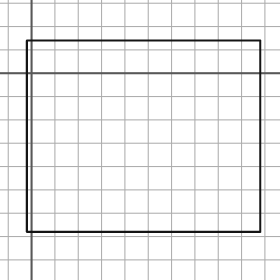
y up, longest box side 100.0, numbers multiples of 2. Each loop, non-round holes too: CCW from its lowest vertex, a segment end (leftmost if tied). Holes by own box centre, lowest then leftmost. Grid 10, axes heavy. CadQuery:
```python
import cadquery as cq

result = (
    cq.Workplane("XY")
    .moveTo(-2.0, -68.0)
    .lineTo(98.0, -68.0)
    .lineTo(98.0, 14.0)
    .lineTo(-2.0, 14.0)
    .close()
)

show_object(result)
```